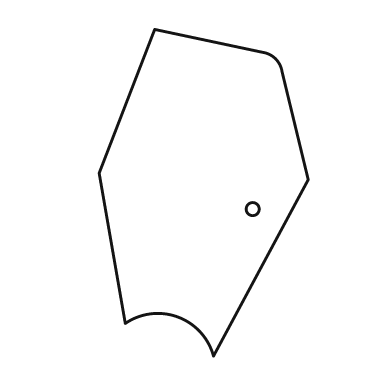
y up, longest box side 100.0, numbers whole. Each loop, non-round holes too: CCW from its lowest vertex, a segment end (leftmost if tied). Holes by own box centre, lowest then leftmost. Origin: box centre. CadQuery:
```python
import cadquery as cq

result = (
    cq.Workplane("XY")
    .moveTo(3.0, -50.0)
    .lineTo(32.0, 4.0)
    .lineTo(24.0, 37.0)
    .threePointArc((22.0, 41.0), (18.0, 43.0))
    .lineTo(-15.0, 50.0)
    .lineTo(-32.0, 6.0)
    .lineTo(-24.0, -40.0)
    .threePointArc((-8.0, -38.0), (3.0, -50.0))
    .close()
    .moveTo(15.0, -5.0)
    .circle(2.0)
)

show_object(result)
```